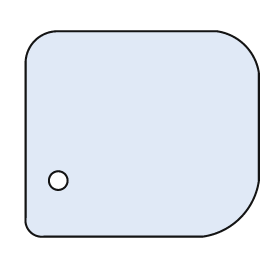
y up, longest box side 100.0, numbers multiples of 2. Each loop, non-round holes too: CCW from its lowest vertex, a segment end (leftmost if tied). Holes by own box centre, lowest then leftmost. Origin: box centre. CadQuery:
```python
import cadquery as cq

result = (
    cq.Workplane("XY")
    .moveTo(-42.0, -44.0)
    .lineTo(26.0, -44.0)
    .threePointArc((42.0, -36.0), (50.0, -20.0))
    .lineTo(50.0, 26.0)
    .threePointArc((44.0, 38.0), (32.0, 44.0))
    .lineTo(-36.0, 44.0)
    .threePointArc((-46.0, 40.0), (-50.0, 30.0))
    .lineTo(-50.0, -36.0)
    .threePointArc((-48.0, -42.0), (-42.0, -44.0))
    .close()
    .moveTo(-36.0, -20.0)
    .circle(4.0)
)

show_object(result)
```